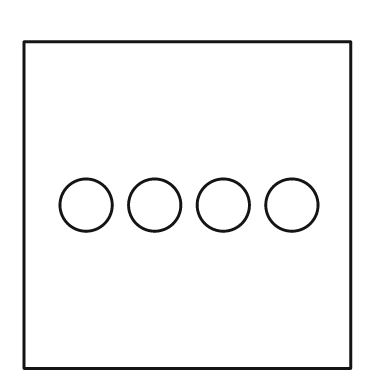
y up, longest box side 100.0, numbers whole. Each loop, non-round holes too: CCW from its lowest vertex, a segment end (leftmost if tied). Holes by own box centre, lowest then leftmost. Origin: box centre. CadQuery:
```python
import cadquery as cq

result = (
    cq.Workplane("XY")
    .moveTo(-50.0, -50.0)
    .lineTo(50.0, -50.0)
    .lineTo(50.0, 50.0)
    .lineTo(-50.0, 50.0)
    .close()
    .moveTo(-31.0, 0.0)
    .circle(8.0)
    .moveTo(-10.0, 0.0)
    .circle(8.0)
    .moveTo(11.0, 0.0)
    .circle(8.0)
    .moveTo(32.0, 0.0)
    .circle(8.0)
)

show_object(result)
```